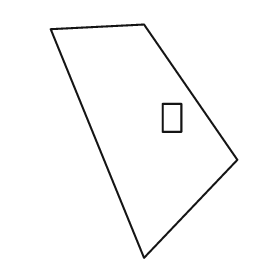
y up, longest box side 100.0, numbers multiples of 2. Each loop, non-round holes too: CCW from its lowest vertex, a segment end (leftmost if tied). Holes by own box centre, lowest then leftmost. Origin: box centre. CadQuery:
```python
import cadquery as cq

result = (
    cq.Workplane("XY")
    .moveTo(0.0, -50.0)
    .lineTo(40.0, -8.0)
    .lineTo(0.0, 50.0)
    .lineTo(-40.0, 48.0)
    .close()
    .moveTo(8.0, 4.0)
    .lineTo(16.0, 4.0)
    .lineTo(16.0, 16.0)
    .lineTo(8.0, 16.0)
    .close()
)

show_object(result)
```